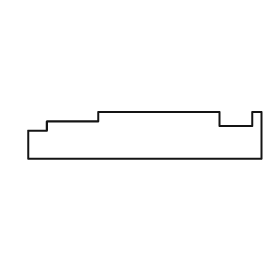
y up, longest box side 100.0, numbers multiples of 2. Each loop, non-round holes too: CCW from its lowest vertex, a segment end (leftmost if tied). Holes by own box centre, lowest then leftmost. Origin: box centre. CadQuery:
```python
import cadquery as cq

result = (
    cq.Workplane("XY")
    .moveTo(-50.0, -10.0)
    .lineTo(50.0, -10.0)
    .lineTo(50.0, 10.0)
    .lineTo(46.0, 10.0)
    .lineTo(46.0, 4.0)
    .lineTo(32.0, 4.0)
    .lineTo(32.0, 10.0)
    .lineTo(-20.0, 10.0)
    .lineTo(-20.0, 6.0)
    .lineTo(-42.0, 6.0)
    .lineTo(-42.0, 2.0)
    .lineTo(-50.0, 2.0)
    .close()
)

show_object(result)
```